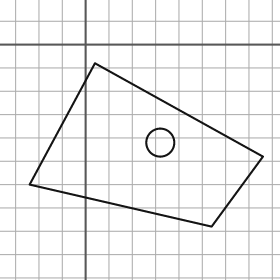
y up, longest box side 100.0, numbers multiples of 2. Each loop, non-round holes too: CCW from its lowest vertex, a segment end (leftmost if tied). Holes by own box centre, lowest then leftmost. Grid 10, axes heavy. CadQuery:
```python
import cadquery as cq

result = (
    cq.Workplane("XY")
    .moveTo(54.0, -78.0)
    .lineTo(76.0, -48.0)
    .lineTo(4.0, -8.0)
    .lineTo(-24.0, -60.0)
    .close()
    .moveTo(32.0, -42.0)
    .circle(6.0)
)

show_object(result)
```